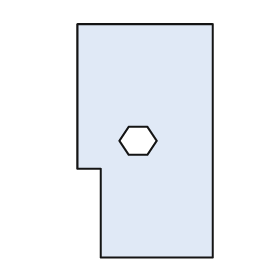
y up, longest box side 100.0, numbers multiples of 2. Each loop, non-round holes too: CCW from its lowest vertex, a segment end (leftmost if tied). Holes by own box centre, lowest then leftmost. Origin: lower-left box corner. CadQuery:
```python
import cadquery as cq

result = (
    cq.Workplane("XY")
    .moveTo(10.0, 0.0)
    .lineTo(58.0, 0.0)
    .lineTo(58.0, 100.0)
    .lineTo(0.0, 100.0)
    .lineTo(0.0, 38.0)
    .lineTo(10.0, 38.0)
    .close()
    .moveTo(22.0, 44.0)
    .lineTo(30.0, 44.0)
    .lineTo(34.0, 50.0)
    .lineTo(30.0, 56.0)
    .lineTo(22.0, 56.0)
    .lineTo(18.0, 50.0)
    .close()
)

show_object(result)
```